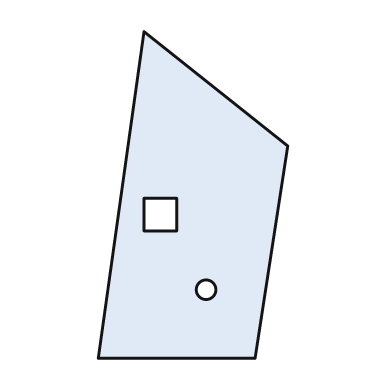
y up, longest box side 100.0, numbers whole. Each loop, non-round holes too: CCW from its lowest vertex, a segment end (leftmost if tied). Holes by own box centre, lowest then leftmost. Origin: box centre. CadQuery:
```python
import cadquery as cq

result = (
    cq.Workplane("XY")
    .moveTo(-29.0, -50.0)
    .lineTo(19.0, -50.0)
    .lineTo(29.0, 15.0)
    .lineTo(-15.0, 50.0)
    .close()
    .moveTo(4.0, -29.0)
    .circle(3.0)
    .moveTo(-15.0, -11.0)
    .lineTo(-5.0, -11.0)
    .lineTo(-5.0, -1.0)
    .lineTo(-15.0, -1.0)
    .close()
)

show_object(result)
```